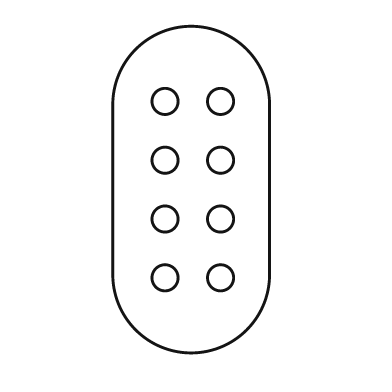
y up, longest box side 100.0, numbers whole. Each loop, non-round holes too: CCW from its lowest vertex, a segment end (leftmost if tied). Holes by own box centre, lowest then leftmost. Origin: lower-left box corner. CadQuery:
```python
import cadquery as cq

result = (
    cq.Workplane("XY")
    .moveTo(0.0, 24.0)
    .threePointArc((24.0, 0.0), (48.0, 24.0))
    .lineTo(48.0, 76.0)
    .threePointArc((24.0, 100.0), (0.0, 76.0))
    .close()
    .moveTo(16.0, 23.0)
    .circle(4.0)
    .moveTo(33.0, 23.0)
    .circle(4.0)
    .moveTo(16.0, 41.0)
    .circle(4.0)
    .moveTo(33.0, 41.0)
    .circle(4.0)
    .moveTo(16.0, 59.0)
    .circle(4.0)
    .moveTo(33.0, 59.0)
    .circle(4.0)
    .moveTo(16.0, 77.0)
    .circle(4.0)
    .moveTo(33.0, 77.0)
    .circle(4.0)
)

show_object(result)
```